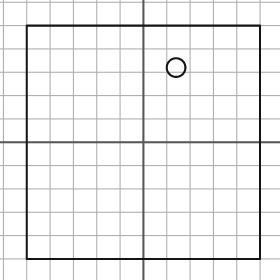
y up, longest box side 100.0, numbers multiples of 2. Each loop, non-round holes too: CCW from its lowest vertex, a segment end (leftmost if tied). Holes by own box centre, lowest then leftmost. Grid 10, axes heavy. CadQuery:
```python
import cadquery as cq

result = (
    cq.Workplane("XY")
    .moveTo(-50.0, -50.0)
    .lineTo(50.0, -50.0)
    .lineTo(50.0, 50.0)
    .lineTo(-50.0, 50.0)
    .close()
    .moveTo(14.0, 32.0)
    .circle(4.0)
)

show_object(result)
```